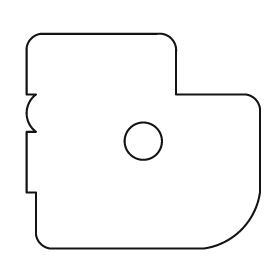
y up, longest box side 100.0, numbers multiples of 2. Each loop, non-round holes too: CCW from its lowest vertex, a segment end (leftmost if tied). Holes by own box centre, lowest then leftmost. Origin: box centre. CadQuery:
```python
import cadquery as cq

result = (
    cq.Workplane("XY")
    .moveTo(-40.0, -46.0)
    .lineTo(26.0, -46.0)
    .threePointArc((42.0, -38.0), (50.0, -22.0))
    .lineTo(50.0, 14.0)
    .threePointArc((48.0, 18.0), (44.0, 20.0))
    .lineTo(14.0, 20.0)
    .lineTo(14.0, 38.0)
    .threePointArc((12.0, 44.0), (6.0, 46.0))
    .lineTo(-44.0, 46.0)
    .threePointArc((-48.0, 44.0), (-50.0, 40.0))
    .lineTo(-50.0, 20.0)
    .lineTo(-46.0, 20.0)
    .threePointArc((-50.0, 12.0), (-46.0, 4.0))
    .lineTo(-50.0, 4.0)
    .lineTo(-50.0, -22.0)
    .lineTo(-46.0, -22.0)
    .lineTo(-46.0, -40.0)
    .threePointArc((-44.0, -44.0), (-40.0, -46.0))
    .close()
    .moveTo(0.0, 0.0)
    .circle(8.0)
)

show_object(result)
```